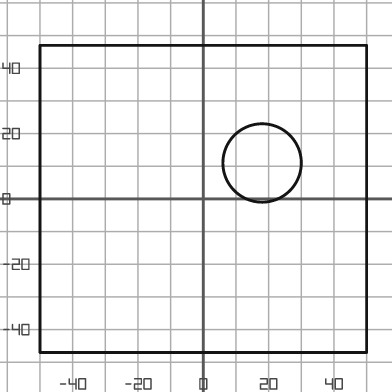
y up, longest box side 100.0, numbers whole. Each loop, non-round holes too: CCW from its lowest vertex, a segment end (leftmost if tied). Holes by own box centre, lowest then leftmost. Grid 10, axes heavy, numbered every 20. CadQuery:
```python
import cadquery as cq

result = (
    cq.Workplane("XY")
    .moveTo(-50.0, -47.0)
    .lineTo(50.0, -47.0)
    .lineTo(50.0, 47.0)
    .lineTo(-50.0, 47.0)
    .close()
    .moveTo(18.0, 11.0)
    .circle(12.0)
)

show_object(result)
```